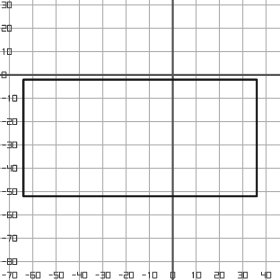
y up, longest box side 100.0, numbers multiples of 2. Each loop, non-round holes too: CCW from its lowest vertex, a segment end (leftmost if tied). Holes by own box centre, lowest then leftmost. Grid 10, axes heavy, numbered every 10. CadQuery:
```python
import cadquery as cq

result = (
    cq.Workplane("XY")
    .moveTo(-64.0, -52.0)
    .lineTo(36.0, -52.0)
    .lineTo(36.0, -2.0)
    .lineTo(-64.0, -2.0)
    .close()
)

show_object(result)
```